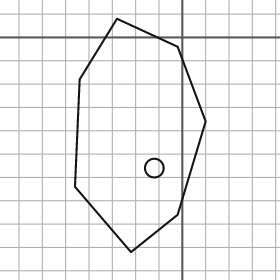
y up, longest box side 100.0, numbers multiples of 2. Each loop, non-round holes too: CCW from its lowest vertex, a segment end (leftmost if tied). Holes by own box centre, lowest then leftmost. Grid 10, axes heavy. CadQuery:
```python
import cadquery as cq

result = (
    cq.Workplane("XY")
    .moveTo(-22.0, -92.0)
    .lineTo(-2.0, -76.0)
    .lineTo(10.0, -36.0)
    .lineTo(-2.0, -4.0)
    .lineTo(-28.0, 8.0)
    .lineTo(-44.0, -18.0)
    .lineTo(-46.0, -64.0)
    .close()
    .moveTo(-12.0, -56.0)
    .circle(4.0)
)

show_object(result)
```